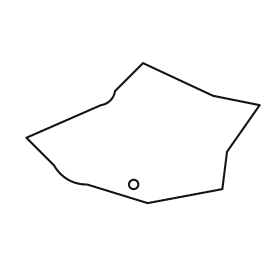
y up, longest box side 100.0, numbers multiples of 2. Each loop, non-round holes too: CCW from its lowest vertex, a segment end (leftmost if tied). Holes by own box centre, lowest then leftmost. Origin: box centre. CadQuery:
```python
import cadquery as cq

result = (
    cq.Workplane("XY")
    .moveTo(2.0, -30.0)
    .lineTo(34.0, -24.0)
    .lineTo(36.0, -8.0)
    .lineTo(50.0, 12.0)
    .lineTo(30.0, 16.0)
    .lineTo(0.0, 30.0)
    .lineTo(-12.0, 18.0)
    .threePointArc((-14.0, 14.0), (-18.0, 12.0))
    .lineTo(-50.0, -2.0)
    .lineTo(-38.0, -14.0)
    .threePointArc((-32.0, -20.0), (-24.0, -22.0))
    .close()
    .moveTo(-4.0, -22.0)
    .circle(2.0)
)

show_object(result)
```